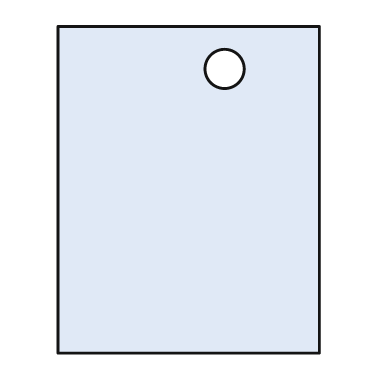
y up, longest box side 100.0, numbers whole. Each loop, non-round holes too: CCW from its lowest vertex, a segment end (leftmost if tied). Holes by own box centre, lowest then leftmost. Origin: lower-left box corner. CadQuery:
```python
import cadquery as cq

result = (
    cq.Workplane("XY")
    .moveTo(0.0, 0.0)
    .lineTo(80.0, 0.0)
    .lineTo(80.0, 100.0)
    .lineTo(0.0, 100.0)
    .close()
    .moveTo(51.0, 87.0)
    .circle(6.0)
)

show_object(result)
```